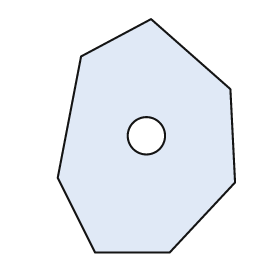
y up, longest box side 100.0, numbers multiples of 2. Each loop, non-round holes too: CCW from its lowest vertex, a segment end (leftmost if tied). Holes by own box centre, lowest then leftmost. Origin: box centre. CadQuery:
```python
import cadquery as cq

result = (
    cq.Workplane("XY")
    .moveTo(-22.0, -50.0)
    .lineTo(10.0, -50.0)
    .lineTo(38.0, -20.0)
    .lineTo(36.0, 20.0)
    .lineTo(2.0, 50.0)
    .lineTo(-28.0, 34.0)
    .lineTo(-38.0, -18.0)
    .close()
    .moveTo(0.0, 0.0)
    .circle(8.0)
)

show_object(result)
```